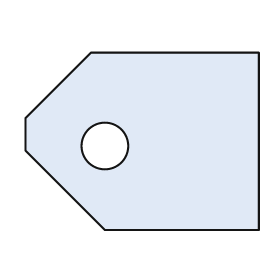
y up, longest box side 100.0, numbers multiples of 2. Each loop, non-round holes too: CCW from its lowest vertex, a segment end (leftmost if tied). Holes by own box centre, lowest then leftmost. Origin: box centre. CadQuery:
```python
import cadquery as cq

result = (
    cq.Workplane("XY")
    .moveTo(-16.0, -38.0)
    .lineTo(50.0, -38.0)
    .lineTo(50.0, 38.0)
    .lineTo(-22.0, 38.0)
    .lineTo(-50.0, 10.0)
    .lineTo(-50.0, -4.0)
    .close()
    .moveTo(-16.0, -2.0)
    .circle(10.0)
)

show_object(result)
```